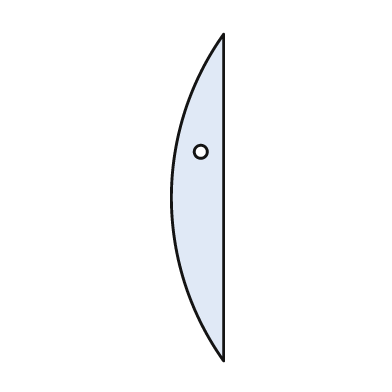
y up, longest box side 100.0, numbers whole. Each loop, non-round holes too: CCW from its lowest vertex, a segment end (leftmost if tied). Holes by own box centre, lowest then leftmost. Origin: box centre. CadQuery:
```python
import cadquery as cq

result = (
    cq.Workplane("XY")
    .moveTo(8.0, -50.0)
    .lineTo(8.0, 50.0)
    .threePointArc((-8.0, 0.0), (8.0, -50.0))
    .close()
    .moveTo(1.0, 14.0)
    .circle(2.0)
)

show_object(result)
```